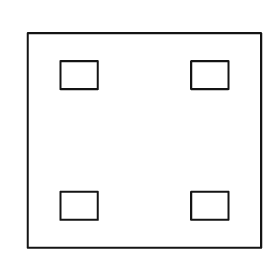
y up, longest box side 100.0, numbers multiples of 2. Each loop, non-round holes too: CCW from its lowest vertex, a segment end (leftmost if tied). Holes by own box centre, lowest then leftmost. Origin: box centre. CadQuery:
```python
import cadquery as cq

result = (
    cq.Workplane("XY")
    .moveTo(-50.0, -46.0)
    .lineTo(50.0, -46.0)
    .lineTo(50.0, 46.0)
    .lineTo(-50.0, 46.0)
    .close()
    .moveTo(-36.0, -34.0)
    .lineTo(-20.0, -34.0)
    .lineTo(-20.0, -22.0)
    .lineTo(-36.0, -22.0)
    .close()
    .moveTo(20.0, -34.0)
    .lineTo(36.0, -34.0)
    .lineTo(36.0, -22.0)
    .lineTo(20.0, -22.0)
    .close()
    .moveTo(-36.0, 22.0)
    .lineTo(-20.0, 22.0)
    .lineTo(-20.0, 34.0)
    .lineTo(-36.0, 34.0)
    .close()
    .moveTo(20.0, 22.0)
    .lineTo(36.0, 22.0)
    .lineTo(36.0, 34.0)
    .lineTo(20.0, 34.0)
    .close()
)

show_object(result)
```